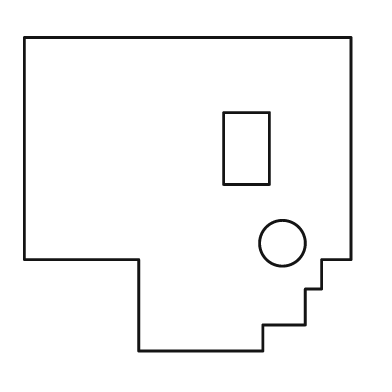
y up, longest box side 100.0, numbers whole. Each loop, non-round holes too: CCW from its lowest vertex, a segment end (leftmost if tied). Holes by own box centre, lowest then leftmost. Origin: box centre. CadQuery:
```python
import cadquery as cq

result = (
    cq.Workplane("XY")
    .moveTo(-15.0, -48.0)
    .lineTo(23.0, -48.0)
    .lineTo(23.0, -40.0)
    .lineTo(36.0, -40.0)
    .lineTo(36.0, -29.0)
    .lineTo(41.0, -29.0)
    .lineTo(41.0, -20.0)
    .lineTo(50.0, -20.0)
    .lineTo(50.0, 48.0)
    .lineTo(-50.0, 48.0)
    .lineTo(-50.0, -20.0)
    .lineTo(-15.0, -20.0)
    .close()
    .moveTo(29.0, -15.0)
    .circle(7.0)
    .moveTo(11.0, 3.0)
    .lineTo(25.0, 3.0)
    .lineTo(25.0, 25.0)
    .lineTo(11.0, 25.0)
    .close()
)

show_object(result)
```